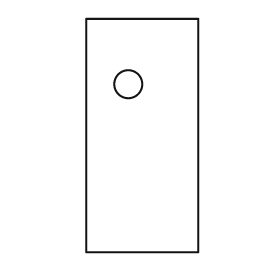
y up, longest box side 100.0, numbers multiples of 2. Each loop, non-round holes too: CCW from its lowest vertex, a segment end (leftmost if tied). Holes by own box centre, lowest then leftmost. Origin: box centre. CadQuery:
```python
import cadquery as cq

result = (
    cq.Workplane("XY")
    .moveTo(-24.0, -50.0)
    .lineTo(24.0, -50.0)
    .lineTo(24.0, 50.0)
    .lineTo(-24.0, 50.0)
    .close()
    .moveTo(-6.0, 22.0)
    .circle(6.0)
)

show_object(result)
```